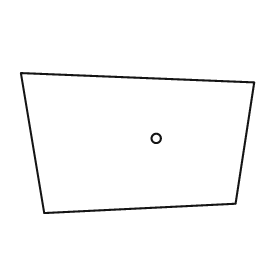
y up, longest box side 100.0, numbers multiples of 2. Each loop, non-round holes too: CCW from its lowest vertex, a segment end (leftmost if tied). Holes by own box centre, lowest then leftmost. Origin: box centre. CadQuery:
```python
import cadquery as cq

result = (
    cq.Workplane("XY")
    .moveTo(-40.0, -30.0)
    .lineTo(42.0, -26.0)
    .lineTo(50.0, 26.0)
    .lineTo(-50.0, 30.0)
    .close()
    .moveTo(8.0, 2.0)
    .circle(2.0)
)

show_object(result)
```